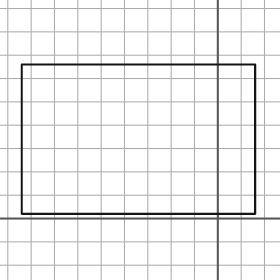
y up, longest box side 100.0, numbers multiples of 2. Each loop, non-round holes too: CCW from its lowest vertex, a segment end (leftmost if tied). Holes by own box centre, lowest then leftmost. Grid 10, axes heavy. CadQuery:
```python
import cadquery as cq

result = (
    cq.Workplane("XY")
    .moveTo(-84.0, 2.0)
    .lineTo(16.0, 2.0)
    .lineTo(16.0, 66.0)
    .lineTo(-84.0, 66.0)
    .close()
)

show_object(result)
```